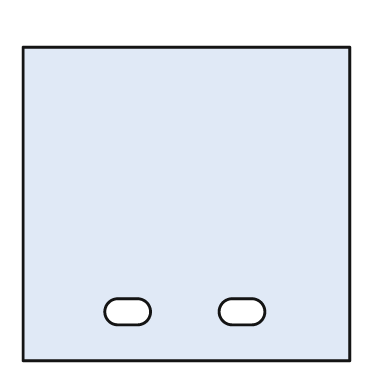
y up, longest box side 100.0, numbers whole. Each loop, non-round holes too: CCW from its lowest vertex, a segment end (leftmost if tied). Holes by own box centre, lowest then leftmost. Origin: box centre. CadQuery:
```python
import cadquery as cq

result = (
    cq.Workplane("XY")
    .moveTo(-50.0, -48.0)
    .lineTo(50.0, -48.0)
    .lineTo(50.0, 48.0)
    .lineTo(-50.0, 48.0)
    .close()
    .moveTo(-21.0, -37.0)
    .lineTo(-15.0, -37.0)
    .threePointArc((-11.0, -33.0), (-15.0, -29.0))
    .lineTo(-21.0, -29.0)
    .threePointArc((-25.0, -33.0), (-21.0, -37.0))
    .close()
    .moveTo(14.0, -37.0)
    .lineTo(20.0, -37.0)
    .threePointArc((24.0, -33.0), (20.0, -29.0))
    .lineTo(14.0, -29.0)
    .threePointArc((10.0, -33.0), (14.0, -37.0))
    .close()
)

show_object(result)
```